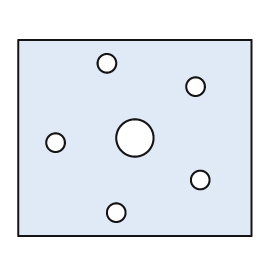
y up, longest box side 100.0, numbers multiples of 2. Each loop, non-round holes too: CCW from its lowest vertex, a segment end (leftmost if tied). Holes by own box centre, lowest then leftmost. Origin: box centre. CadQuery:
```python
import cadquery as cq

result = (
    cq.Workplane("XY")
    .moveTo(-50.0, -42.0)
    .lineTo(50.0, -42.0)
    .lineTo(50.0, 42.0)
    .lineTo(-50.0, 42.0)
    .close()
    .moveTo(-8.0, -32.0)
    .circle(4.0)
    .moveTo(28.0, -18.0)
    .circle(4.0)
    .moveTo(-34.0, -2.0)
    .circle(4.0)
    .moveTo(0.0, 0.0)
    .circle(8.0)
    .moveTo(26.0, 22.0)
    .circle(4.0)
    .moveTo(-12.0, 32.0)
    .circle(4.0)
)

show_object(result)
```